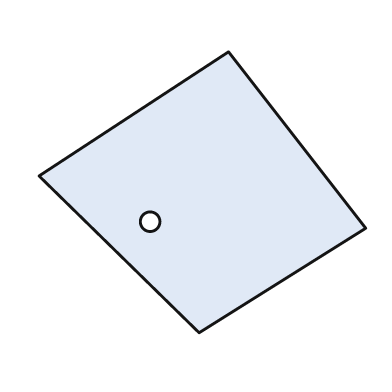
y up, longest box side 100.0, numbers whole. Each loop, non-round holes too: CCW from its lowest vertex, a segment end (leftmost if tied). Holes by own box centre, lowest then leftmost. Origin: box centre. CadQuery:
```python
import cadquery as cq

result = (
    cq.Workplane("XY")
    .moveTo(-1.0, -43.0)
    .lineTo(50.0, -11.0)
    .lineTo(8.0, 43.0)
    .lineTo(-50.0, 5.0)
    .close()
    .moveTo(-16.0, -9.0)
    .circle(3.0)
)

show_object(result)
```